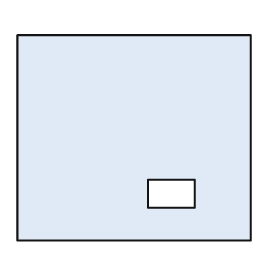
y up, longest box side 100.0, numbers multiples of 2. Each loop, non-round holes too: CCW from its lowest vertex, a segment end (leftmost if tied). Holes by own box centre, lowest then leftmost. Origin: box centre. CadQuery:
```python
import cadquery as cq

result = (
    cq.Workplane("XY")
    .moveTo(-50.0, -44.0)
    .lineTo(50.0, -44.0)
    .lineTo(50.0, 44.0)
    .lineTo(-50.0, 44.0)
    .close()
    .moveTo(6.0, -30.0)
    .lineTo(26.0, -30.0)
    .lineTo(26.0, -18.0)
    .lineTo(6.0, -18.0)
    .close()
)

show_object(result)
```